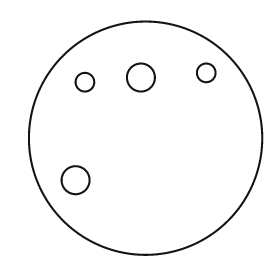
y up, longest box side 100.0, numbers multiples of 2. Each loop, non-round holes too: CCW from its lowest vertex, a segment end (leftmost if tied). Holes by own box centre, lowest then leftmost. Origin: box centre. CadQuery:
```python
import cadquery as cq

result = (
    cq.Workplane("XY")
    .moveTo(0.0, 0.0)
    .circle(50.0)
    .moveTo(-30.0, -18.0)
    .circle(6.0)
    .moveTo(-26.0, 24.0)
    .circle(4.0)
    .moveTo(-2.0, 26.0)
    .circle(6.0)
    .moveTo(26.0, 28.0)
    .circle(4.0)
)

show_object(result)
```